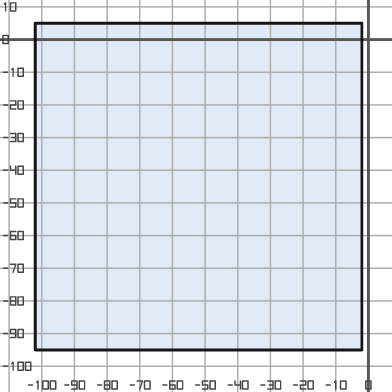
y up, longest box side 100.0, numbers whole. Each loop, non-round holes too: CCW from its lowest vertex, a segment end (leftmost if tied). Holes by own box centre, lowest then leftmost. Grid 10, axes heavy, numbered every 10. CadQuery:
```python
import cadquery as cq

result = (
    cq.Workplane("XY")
    .moveTo(-102.0, -95.0)
    .lineTo(-2.0, -95.0)
    .lineTo(-2.0, 5.0)
    .lineTo(-102.0, 5.0)
    .close()
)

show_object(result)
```